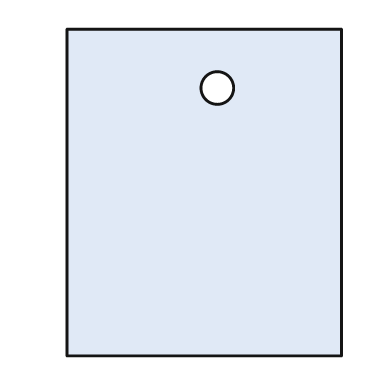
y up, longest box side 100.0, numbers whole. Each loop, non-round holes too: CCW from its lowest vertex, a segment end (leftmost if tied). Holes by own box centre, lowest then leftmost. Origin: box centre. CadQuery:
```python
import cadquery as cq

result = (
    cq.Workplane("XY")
    .moveTo(-42.0, -50.0)
    .lineTo(42.0, -50.0)
    .lineTo(42.0, 50.0)
    .lineTo(-42.0, 50.0)
    .close()
    .moveTo(4.0, 32.0)
    .circle(5.0)
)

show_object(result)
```